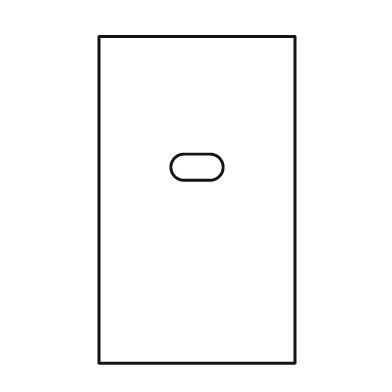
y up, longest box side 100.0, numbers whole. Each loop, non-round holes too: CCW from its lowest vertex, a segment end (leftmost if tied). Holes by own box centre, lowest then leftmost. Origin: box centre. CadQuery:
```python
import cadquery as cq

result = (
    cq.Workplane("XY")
    .moveTo(-30.0, -50.0)
    .lineTo(30.0, -50.0)
    .lineTo(30.0, 50.0)
    .lineTo(-30.0, 50.0)
    .close()
    .moveTo(-4.0, 6.0)
    .lineTo(4.0, 6.0)
    .threePointArc((8.0, 10.0), (4.0, 14.0))
    .lineTo(-4.0, 14.0)
    .threePointArc((-8.0, 10.0), (-4.0, 6.0))
    .close()
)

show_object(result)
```